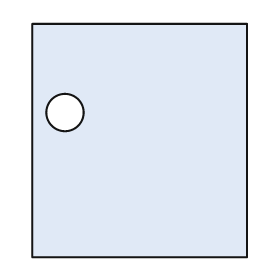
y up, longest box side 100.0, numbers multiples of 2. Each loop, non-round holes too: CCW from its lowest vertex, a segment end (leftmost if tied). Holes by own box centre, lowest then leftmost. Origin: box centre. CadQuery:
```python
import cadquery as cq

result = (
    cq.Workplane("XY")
    .moveTo(-46.0, -50.0)
    .lineTo(46.0, -50.0)
    .lineTo(46.0, 50.0)
    .lineTo(-46.0, 50.0)
    .close()
    .moveTo(-32.0, 12.0)
    .circle(8.0)
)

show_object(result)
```